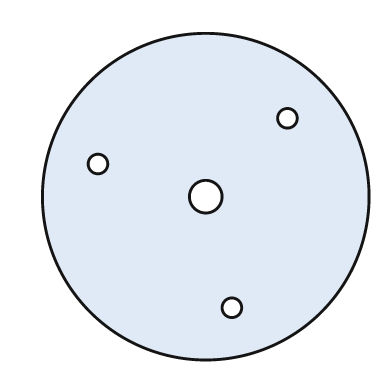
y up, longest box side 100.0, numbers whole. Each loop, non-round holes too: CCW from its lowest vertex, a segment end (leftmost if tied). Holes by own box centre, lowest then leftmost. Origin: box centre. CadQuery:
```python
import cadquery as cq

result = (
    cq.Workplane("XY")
    .moveTo(0.0, 0.0)
    .circle(50.0)
    .moveTo(8.0, -34.0)
    .circle(3.0)
    .moveTo(0.0, 0.0)
    .circle(5.0)
    .moveTo(-33.0, 10.0)
    .circle(3.0)
    .moveTo(25.0, 24.0)
    .circle(3.0)
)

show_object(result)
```